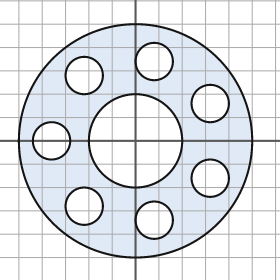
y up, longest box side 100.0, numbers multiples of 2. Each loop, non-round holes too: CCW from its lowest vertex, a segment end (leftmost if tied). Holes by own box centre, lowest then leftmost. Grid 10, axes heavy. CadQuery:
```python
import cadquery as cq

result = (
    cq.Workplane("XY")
    .moveTo(0.0, 0.0)
    .circle(50.0)
    .moveTo(8.0, -34.0)
    .circle(8.0)
    .moveTo(-22.0, -28.0)
    .circle(8.0)
    .moveTo(32.0, -16.0)
    .circle(8.0)
    .moveTo(-36.0, 0.0)
    .circle(8.0)
    .moveTo(0.0, 0.0)
    .circle(20.0)
    .moveTo(32.0, 16.0)
    .circle(8.0)
    .moveTo(-22.0, 28.0)
    .circle(8.0)
    .moveTo(8.0, 34.0)
    .circle(8.0)
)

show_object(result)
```